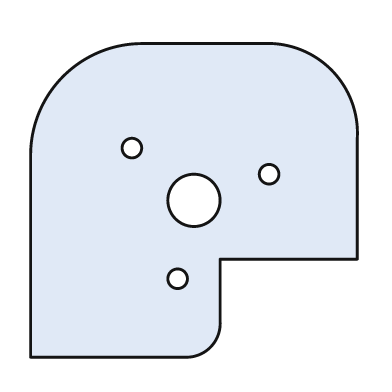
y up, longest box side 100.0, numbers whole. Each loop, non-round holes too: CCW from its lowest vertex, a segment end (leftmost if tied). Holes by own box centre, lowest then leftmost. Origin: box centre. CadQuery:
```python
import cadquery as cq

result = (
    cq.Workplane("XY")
    .moveTo(-50.0, -48.0)
    .lineTo(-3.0, -48.0)
    .threePointArc((5.0, -45.0), (8.0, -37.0))
    .lineTo(8.0, -18.0)
    .lineTo(50.0, -18.0)
    .lineTo(50.0, 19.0)
    .threePointArc((42.0, 40.0), (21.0, 48.0))
    .lineTo(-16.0, 48.0)
    .threePointArc((-40.0, 38.0), (-50.0, 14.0))
    .close()
    .moveTo(-5.0, -24.0)
    .circle(3.0)
    .moveTo(0.0, 0.0)
    .circle(8.0)
    .moveTo(23.0, 8.0)
    .circle(3.0)
    .moveTo(-19.0, 16.0)
    .circle(3.0)
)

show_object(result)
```